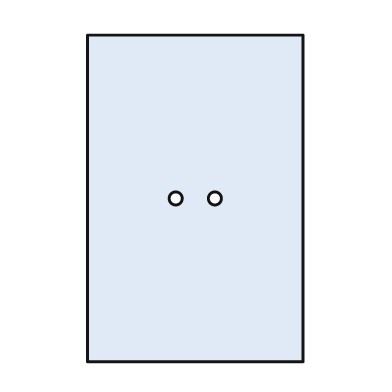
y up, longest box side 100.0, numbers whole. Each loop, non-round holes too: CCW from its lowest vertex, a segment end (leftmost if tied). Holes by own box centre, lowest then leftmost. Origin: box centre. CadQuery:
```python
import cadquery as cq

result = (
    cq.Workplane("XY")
    .moveTo(-33.0, -50.0)
    .lineTo(33.0, -50.0)
    .lineTo(33.0, 50.0)
    .lineTo(-33.0, 50.0)
    .close()
    .moveTo(-6.0, 0.0)
    .circle(2.0)
    .moveTo(6.0, 0.0)
    .circle(2.0)
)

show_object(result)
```